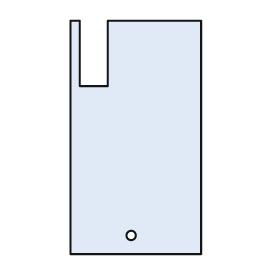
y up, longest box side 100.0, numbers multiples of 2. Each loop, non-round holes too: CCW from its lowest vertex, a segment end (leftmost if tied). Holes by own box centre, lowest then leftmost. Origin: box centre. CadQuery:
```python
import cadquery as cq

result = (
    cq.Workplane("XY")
    .moveTo(-28.0, -50.0)
    .lineTo(28.0, -50.0)
    .lineTo(28.0, 50.0)
    .lineTo(-12.0, 50.0)
    .lineTo(-12.0, 22.0)
    .lineTo(-24.0, 22.0)
    .lineTo(-24.0, 50.0)
    .lineTo(-28.0, 50.0)
    .close()
    .moveTo(-2.0, -42.0)
    .circle(2.0)
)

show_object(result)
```